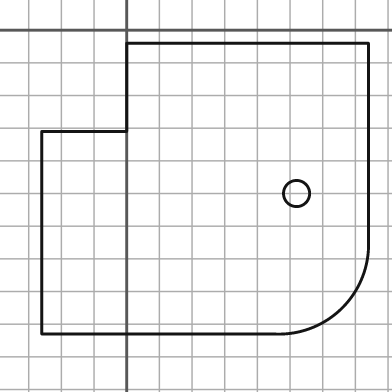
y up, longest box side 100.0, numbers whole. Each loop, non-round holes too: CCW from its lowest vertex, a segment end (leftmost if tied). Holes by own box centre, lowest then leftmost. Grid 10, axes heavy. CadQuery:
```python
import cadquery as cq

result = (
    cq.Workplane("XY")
    .moveTo(-26.0, -93.0)
    .lineTo(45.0, -93.0)
    .threePointArc((66.0, -85.0), (74.0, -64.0))
    .lineTo(74.0, -4.0)
    .lineTo(0.0, -4.0)
    .lineTo(0.0, -31.0)
    .lineTo(-26.0, -31.0)
    .close()
    .moveTo(52.0, -50.0)
    .circle(4.0)
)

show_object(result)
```